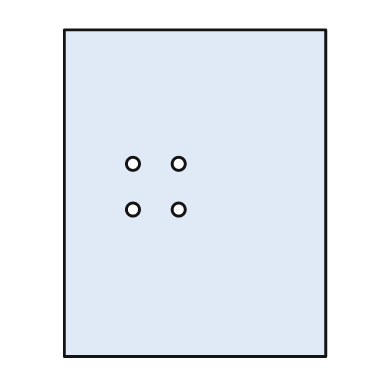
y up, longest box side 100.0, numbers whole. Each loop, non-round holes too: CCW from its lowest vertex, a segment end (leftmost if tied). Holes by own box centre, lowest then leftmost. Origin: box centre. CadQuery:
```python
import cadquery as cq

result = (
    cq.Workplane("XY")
    .moveTo(-40.0, -50.0)
    .lineTo(40.0, -50.0)
    .lineTo(40.0, 50.0)
    .lineTo(-40.0, 50.0)
    .close()
    .moveTo(-19.0, -5.0)
    .circle(2.0)
    .moveTo(-5.0, -5.0)
    .circle(2.0)
    .moveTo(-19.0, 9.0)
    .circle(2.0)
    .moveTo(-5.0, 9.0)
    .circle(2.0)
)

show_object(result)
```